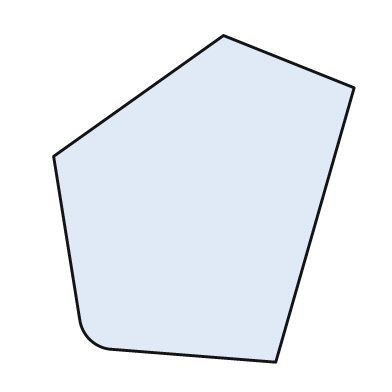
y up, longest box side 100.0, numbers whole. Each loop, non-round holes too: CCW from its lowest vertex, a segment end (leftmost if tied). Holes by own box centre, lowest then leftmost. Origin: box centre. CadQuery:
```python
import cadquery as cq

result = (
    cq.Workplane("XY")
    .moveTo(22.0, -50.0)
    .lineTo(46.0, 34.0)
    .lineTo(6.0, 50.0)
    .lineTo(-46.0, 13.0)
    .lineTo(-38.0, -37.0)
    .threePointArc((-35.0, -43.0), (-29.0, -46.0))
    .close()
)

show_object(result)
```